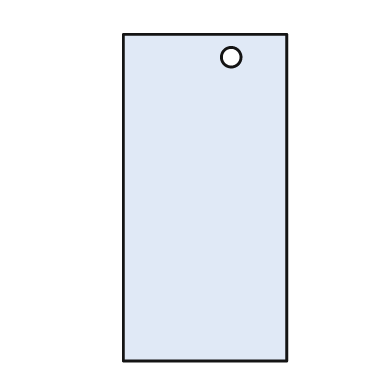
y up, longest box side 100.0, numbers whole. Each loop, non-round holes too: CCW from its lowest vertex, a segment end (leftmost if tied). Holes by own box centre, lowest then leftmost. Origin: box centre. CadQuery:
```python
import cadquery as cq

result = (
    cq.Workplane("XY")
    .moveTo(-25.0, -50.0)
    .lineTo(25.0, -50.0)
    .lineTo(25.0, 50.0)
    .lineTo(-25.0, 50.0)
    .close()
    .moveTo(8.0, 43.0)
    .circle(3.0)
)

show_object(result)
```